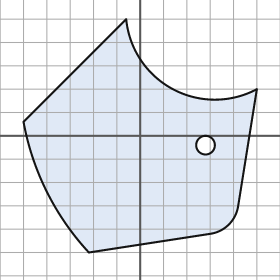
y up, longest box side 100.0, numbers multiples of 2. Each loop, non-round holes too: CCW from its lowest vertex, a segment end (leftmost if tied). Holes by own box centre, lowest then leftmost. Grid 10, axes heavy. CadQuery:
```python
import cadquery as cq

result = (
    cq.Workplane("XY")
    .moveTo(-22.0, -50.0)
    .lineTo(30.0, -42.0)
    .threePointArc((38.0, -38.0), (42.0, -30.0))
    .lineTo(50.0, 20.0)
    .threePointArc((14.0, 20.0), (-6.0, 50.0))
    .lineTo(-50.0, 6.0)
    .threePointArc((-40.0, -24.0), (-22.0, -50.0))
    .close()
    .moveTo(28.0, -4.0)
    .circle(4.0)
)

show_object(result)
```